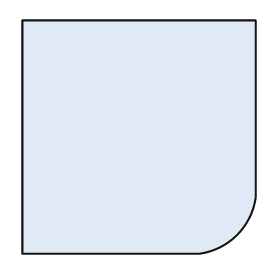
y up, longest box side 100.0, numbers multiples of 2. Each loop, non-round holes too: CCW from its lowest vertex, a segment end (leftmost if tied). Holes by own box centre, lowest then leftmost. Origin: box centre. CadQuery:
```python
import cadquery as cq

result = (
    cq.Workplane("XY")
    .moveTo(-50.0, -50.0)
    .lineTo(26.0, -50.0)
    .threePointArc((42.0, -42.0), (50.0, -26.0))
    .lineTo(50.0, 50.0)
    .lineTo(-50.0, 50.0)
    .close()
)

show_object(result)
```